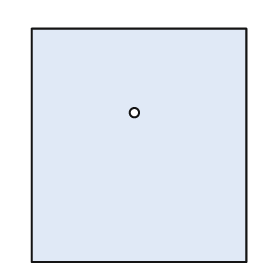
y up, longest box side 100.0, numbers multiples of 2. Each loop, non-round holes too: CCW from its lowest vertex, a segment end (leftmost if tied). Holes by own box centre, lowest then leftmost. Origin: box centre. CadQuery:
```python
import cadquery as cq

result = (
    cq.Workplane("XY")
    .moveTo(-46.0, -50.0)
    .lineTo(46.0, -50.0)
    .lineTo(46.0, 50.0)
    .lineTo(-46.0, 50.0)
    .close()
    .moveTo(-2.0, 14.0)
    .circle(2.0)
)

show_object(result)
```